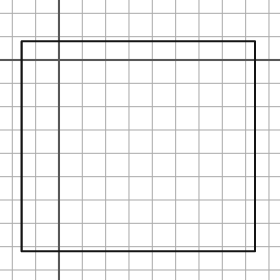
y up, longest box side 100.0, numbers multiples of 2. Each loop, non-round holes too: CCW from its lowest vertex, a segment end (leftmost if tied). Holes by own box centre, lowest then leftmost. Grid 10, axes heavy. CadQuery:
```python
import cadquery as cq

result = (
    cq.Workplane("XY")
    .moveTo(-16.0, -82.0)
    .lineTo(84.0, -82.0)
    .lineTo(84.0, 8.0)
    .lineTo(-16.0, 8.0)
    .close()
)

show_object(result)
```